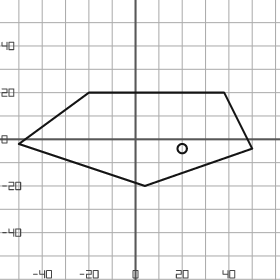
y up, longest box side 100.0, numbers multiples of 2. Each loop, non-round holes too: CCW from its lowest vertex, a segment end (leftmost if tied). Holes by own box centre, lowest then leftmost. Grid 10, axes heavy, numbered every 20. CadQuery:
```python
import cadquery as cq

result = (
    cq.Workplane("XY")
    .moveTo(4.0, -20.0)
    .lineTo(50.0, -4.0)
    .lineTo(38.0, 20.0)
    .lineTo(-20.0, 20.0)
    .lineTo(-50.0, -2.0)
    .close()
    .moveTo(20.0, -4.0)
    .circle(2.0)
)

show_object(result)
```